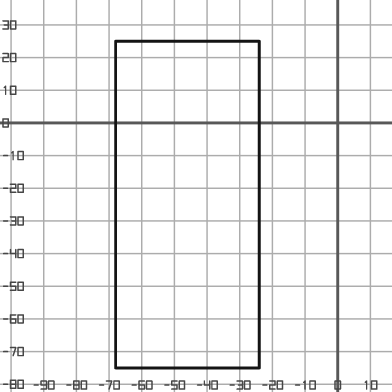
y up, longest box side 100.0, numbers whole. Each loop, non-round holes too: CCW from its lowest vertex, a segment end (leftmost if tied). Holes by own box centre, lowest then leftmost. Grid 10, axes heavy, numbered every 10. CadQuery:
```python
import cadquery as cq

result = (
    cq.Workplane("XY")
    .moveTo(-68.0, -75.0)
    .lineTo(-24.0, -75.0)
    .lineTo(-24.0, 25.0)
    .lineTo(-68.0, 25.0)
    .close()
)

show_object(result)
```